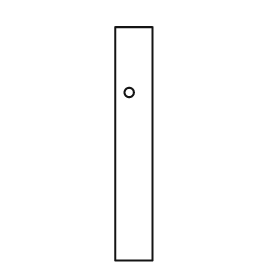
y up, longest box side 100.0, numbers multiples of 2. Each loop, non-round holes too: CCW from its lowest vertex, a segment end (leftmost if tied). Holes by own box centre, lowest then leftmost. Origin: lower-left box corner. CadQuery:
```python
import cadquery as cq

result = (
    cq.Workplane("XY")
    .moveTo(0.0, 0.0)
    .lineTo(16.0, 0.0)
    .lineTo(16.0, 100.0)
    .lineTo(0.0, 100.0)
    .close()
    .moveTo(6.0, 72.0)
    .circle(2.0)
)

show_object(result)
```